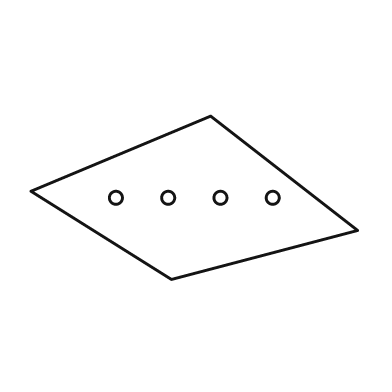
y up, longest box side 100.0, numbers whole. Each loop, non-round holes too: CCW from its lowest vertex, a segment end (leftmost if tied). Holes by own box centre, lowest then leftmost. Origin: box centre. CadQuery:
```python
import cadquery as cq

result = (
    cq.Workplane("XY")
    .moveTo(-7.0, -25.0)
    .lineTo(50.0, -10.0)
    .lineTo(5.0, 25.0)
    .lineTo(-50.0, 2.0)
    .close()
    .moveTo(-24.0, 0.0)
    .circle(2.0)
    .moveTo(-8.0, 0.0)
    .circle(2.0)
    .moveTo(8.0, 0.0)
    .circle(2.0)
    .moveTo(24.0, 0.0)
    .circle(2.0)
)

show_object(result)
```